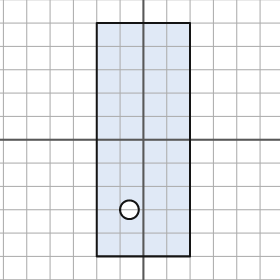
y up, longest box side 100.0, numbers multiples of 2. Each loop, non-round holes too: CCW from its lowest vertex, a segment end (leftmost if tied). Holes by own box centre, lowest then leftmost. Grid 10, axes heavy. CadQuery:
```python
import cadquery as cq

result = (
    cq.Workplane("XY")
    .moveTo(-20.0, -50.0)
    .lineTo(20.0, -50.0)
    .lineTo(20.0, 50.0)
    .lineTo(-20.0, 50.0)
    .close()
    .moveTo(-6.0, -30.0)
    .circle(4.0)
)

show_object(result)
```